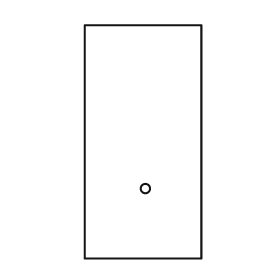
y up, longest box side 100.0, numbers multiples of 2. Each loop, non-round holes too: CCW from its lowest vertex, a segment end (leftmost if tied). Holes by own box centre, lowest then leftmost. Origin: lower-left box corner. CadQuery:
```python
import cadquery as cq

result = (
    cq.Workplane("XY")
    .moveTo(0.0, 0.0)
    .lineTo(50.0, 0.0)
    .lineTo(50.0, 100.0)
    .lineTo(0.0, 100.0)
    .close()
    .moveTo(26.0, 30.0)
    .circle(2.0)
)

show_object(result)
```